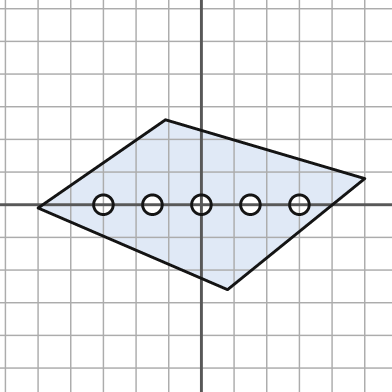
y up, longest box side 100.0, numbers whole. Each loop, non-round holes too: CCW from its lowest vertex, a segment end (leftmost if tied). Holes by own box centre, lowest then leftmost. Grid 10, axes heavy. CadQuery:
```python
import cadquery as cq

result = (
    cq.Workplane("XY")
    .moveTo(8.0, -26.0)
    .lineTo(50.0, 8.0)
    .lineTo(-11.0, 26.0)
    .lineTo(-50.0, -1.0)
    .close()
    .moveTo(-30.0, 0.0)
    .circle(3.0)
    .moveTo(-15.0, 0.0)
    .circle(3.0)
    .moveTo(0.0, 0.0)
    .circle(3.0)
    .moveTo(15.0, 0.0)
    .circle(3.0)
    .moveTo(30.0, 0.0)
    .circle(3.0)
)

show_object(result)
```